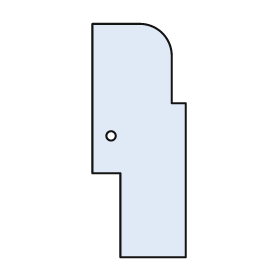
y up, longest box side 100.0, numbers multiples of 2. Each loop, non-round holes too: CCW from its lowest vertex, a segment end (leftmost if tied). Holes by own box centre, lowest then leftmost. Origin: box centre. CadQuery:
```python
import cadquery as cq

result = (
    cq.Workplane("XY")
    .moveTo(-8.0, -50.0)
    .lineTo(20.0, -50.0)
    .lineTo(20.0, 16.0)
    .lineTo(14.0, 16.0)
    .lineTo(14.0, 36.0)
    .threePointArc((10.0, 46.0), (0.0, 50.0))
    .lineTo(-20.0, 50.0)
    .lineTo(-20.0, -14.0)
    .lineTo(-8.0, -14.0)
    .close()
    .moveTo(-12.0, 2.0)
    .circle(2.0)
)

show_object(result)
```